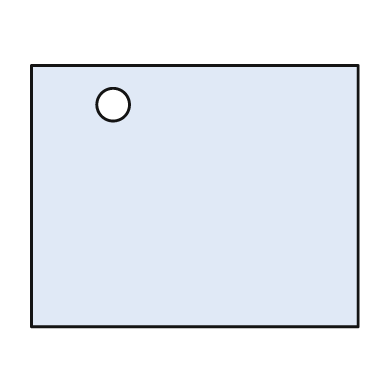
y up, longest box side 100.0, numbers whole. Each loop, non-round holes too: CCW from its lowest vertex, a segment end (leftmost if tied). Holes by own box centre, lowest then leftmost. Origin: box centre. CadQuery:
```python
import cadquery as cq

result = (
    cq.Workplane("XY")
    .moveTo(-50.0, -40.0)
    .lineTo(50.0, -40.0)
    .lineTo(50.0, 40.0)
    .lineTo(-50.0, 40.0)
    .close()
    .moveTo(-25.0, 28.0)
    .circle(5.0)
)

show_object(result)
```